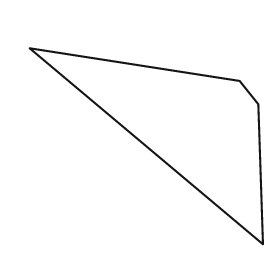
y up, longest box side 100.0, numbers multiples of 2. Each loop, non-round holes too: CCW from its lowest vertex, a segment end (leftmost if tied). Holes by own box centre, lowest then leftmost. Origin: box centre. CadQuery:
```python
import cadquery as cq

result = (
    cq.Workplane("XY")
    .moveTo(50.0, -42.0)
    .lineTo(48.0, 18.0)
    .lineTo(40.0, 28.0)
    .lineTo(-50.0, 42.0)
    .close()
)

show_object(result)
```